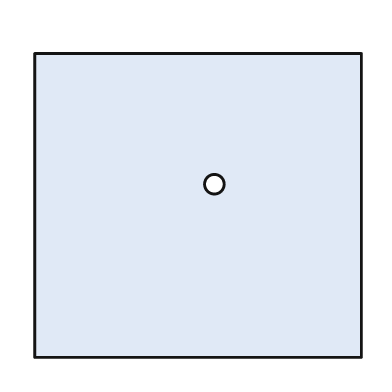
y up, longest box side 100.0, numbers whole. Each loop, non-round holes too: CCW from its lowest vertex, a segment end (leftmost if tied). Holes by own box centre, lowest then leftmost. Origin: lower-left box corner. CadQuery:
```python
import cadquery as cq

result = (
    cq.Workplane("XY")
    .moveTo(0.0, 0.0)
    .lineTo(100.0, 0.0)
    .lineTo(100.0, 93.0)
    .lineTo(0.0, 93.0)
    .close()
    .moveTo(55.0, 53.0)
    .circle(3.0)
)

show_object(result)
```